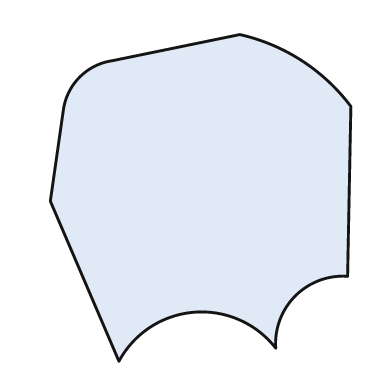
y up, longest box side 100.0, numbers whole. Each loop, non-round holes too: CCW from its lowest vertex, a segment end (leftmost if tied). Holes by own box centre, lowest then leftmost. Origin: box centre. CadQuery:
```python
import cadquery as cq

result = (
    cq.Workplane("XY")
    .moveTo(-25.0, -50.0)
    .threePointArc((-2.0, -35.0), (23.0, -46.0))
    .threePointArc((29.0, -30.0), (45.0, -24.0))
    .lineTo(46.0, 28.0)
    .threePointArc((31.0, 42.0), (12.0, 50.0))
    .lineTo(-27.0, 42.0)
    .threePointArc((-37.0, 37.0), (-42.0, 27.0))
    .lineTo(-46.0, -1.0)
    .close()
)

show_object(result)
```